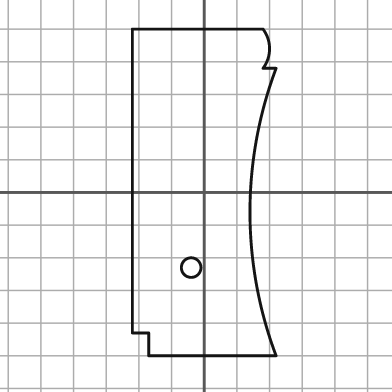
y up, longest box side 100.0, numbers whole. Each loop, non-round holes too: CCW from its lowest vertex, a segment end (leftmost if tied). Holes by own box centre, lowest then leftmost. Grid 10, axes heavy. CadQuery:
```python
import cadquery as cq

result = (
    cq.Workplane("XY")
    .moveTo(-17.0, -50.0)
    .lineTo(22.0, -50.0)
    .threePointArc((14.0, -6.0), (22.0, 38.0))
    .lineTo(18.0, 38.0)
    .threePointArc((20.0, 44.0), (18.0, 50.0))
    .lineTo(-22.0, 50.0)
    .lineTo(-22.0, -43.0)
    .lineTo(-17.0, -43.0)
    .close()
    .moveTo(-4.0, -23.0)
    .circle(3.0)
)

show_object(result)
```